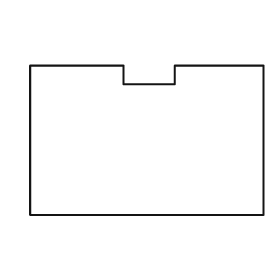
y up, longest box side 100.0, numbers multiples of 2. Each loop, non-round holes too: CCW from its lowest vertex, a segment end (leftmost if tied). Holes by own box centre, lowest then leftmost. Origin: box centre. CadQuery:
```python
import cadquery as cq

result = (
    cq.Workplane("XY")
    .moveTo(-50.0, -32.0)
    .lineTo(50.0, -32.0)
    .lineTo(50.0, 32.0)
    .lineTo(12.0, 32.0)
    .lineTo(12.0, 24.0)
    .lineTo(-10.0, 24.0)
    .lineTo(-10.0, 32.0)
    .lineTo(-50.0, 32.0)
    .close()
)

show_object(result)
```